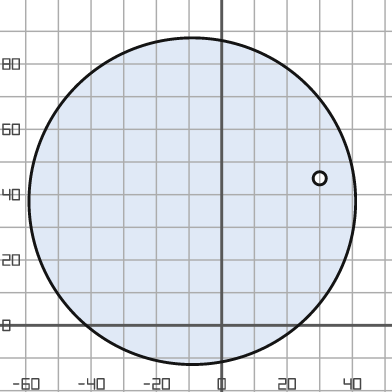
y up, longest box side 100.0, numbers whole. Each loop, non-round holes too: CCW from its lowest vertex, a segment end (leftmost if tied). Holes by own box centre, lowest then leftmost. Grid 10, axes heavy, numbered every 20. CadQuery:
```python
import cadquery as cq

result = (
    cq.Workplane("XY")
    .moveTo(-9.0, 38.0)
    .circle(50.0)
    .moveTo(30.0, 45.0)
    .circle(2.0)
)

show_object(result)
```